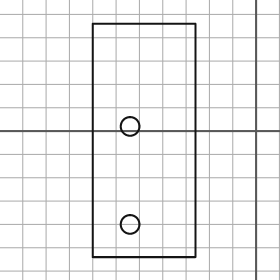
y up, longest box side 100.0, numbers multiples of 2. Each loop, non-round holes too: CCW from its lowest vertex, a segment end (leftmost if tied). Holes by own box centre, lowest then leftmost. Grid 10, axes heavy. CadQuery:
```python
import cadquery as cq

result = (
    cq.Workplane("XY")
    .moveTo(-70.0, -54.0)
    .lineTo(-26.0, -54.0)
    .lineTo(-26.0, 46.0)
    .lineTo(-70.0, 46.0)
    .close()
    .moveTo(-54.0, -40.0)
    .circle(4.0)
    .moveTo(-54.0, 2.0)
    .circle(4.0)
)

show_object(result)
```